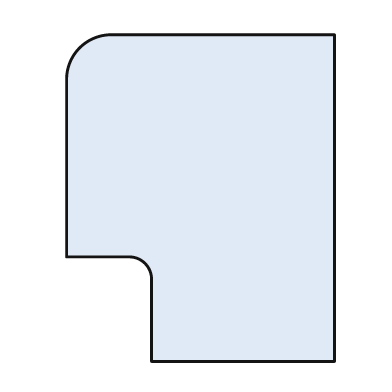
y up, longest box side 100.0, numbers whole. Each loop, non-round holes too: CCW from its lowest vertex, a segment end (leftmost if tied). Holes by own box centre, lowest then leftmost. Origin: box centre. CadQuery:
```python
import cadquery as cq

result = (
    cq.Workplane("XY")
    .moveTo(-15.0, -50.0)
    .lineTo(41.0, -50.0)
    .lineTo(41.0, 50.0)
    .lineTo(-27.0, 50.0)
    .threePointArc((-37.0, 46.0), (-41.0, 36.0))
    .lineTo(-41.0, -18.0)
    .lineTo(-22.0, -18.0)
    .threePointArc((-17.0, -20.0), (-15.0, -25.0))
    .close()
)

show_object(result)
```